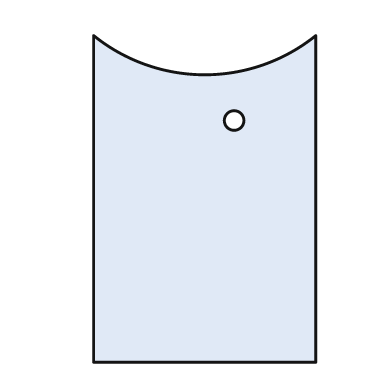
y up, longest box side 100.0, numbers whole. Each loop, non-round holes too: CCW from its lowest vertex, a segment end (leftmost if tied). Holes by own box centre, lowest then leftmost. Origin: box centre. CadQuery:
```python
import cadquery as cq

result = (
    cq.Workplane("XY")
    .moveTo(-34.0, -50.0)
    .lineTo(34.0, -50.0)
    .lineTo(34.0, 50.0)
    .threePointArc((0.0, 38.0), (-34.0, 50.0))
    .close()
    .moveTo(9.0, 24.0)
    .circle(3.0)
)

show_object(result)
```